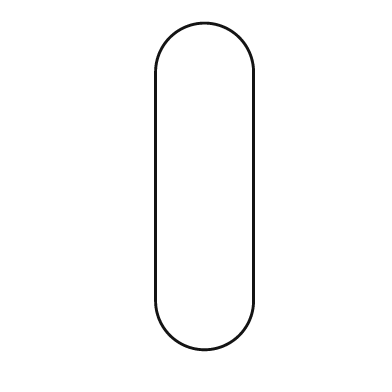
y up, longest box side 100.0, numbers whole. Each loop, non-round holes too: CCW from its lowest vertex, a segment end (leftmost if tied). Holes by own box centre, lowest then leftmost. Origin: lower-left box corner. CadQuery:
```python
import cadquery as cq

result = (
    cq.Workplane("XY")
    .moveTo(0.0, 15.0)
    .threePointArc((15.0, 0.0), (30.0, 15.0))
    .lineTo(30.0, 85.0)
    .threePointArc((15.0, 100.0), (0.0, 85.0))
    .close()
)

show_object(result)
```